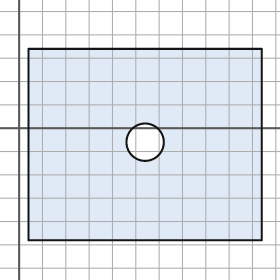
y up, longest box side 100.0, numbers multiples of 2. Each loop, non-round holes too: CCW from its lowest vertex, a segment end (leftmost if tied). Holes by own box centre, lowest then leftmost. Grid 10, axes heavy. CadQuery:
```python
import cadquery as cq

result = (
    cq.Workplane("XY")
    .moveTo(4.0, -48.0)
    .lineTo(104.0, -48.0)
    .lineTo(104.0, 34.0)
    .lineTo(4.0, 34.0)
    .close()
    .moveTo(54.0, -6.0)
    .circle(8.0)
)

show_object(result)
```